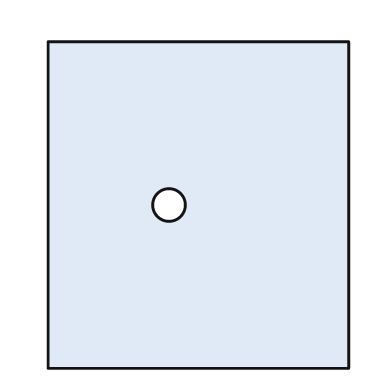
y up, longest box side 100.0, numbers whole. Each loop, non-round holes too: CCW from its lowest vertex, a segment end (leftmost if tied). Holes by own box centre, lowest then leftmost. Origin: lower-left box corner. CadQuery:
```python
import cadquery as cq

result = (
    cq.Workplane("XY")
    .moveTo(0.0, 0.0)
    .lineTo(92.0, 0.0)
    .lineTo(92.0, 100.0)
    .lineTo(0.0, 100.0)
    .close()
    .moveTo(37.0, 50.0)
    .circle(5.0)
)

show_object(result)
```